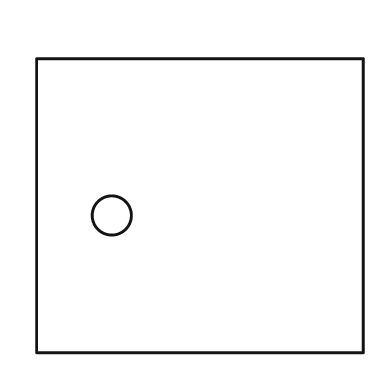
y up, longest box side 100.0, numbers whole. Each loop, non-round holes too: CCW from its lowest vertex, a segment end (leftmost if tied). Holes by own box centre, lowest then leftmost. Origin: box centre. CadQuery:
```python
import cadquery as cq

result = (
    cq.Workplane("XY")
    .moveTo(-50.0, -45.0)
    .lineTo(50.0, -45.0)
    .lineTo(50.0, 45.0)
    .lineTo(-50.0, 45.0)
    .close()
    .moveTo(-27.0, -3.0)
    .circle(6.0)
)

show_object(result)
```